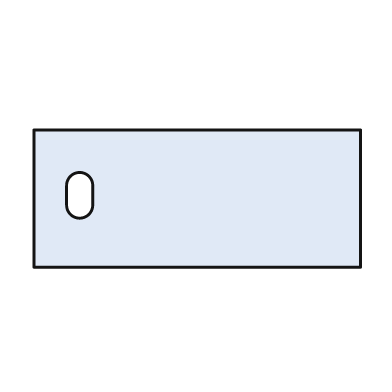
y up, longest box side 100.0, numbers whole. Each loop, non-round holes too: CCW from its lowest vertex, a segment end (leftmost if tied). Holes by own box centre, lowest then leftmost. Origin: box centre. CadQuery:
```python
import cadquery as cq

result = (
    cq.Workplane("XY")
    .moveTo(-50.0, -21.0)
    .lineTo(50.0, -21.0)
    .lineTo(50.0, 21.0)
    .lineTo(-50.0, 21.0)
    .close()
    .moveTo(-40.0, -2.0)
    .threePointArc((-36.0, -6.0), (-32.0, -2.0))
    .lineTo(-32.0, 4.0)
    .threePointArc((-36.0, 8.0), (-40.0, 4.0))
    .close()
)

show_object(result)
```